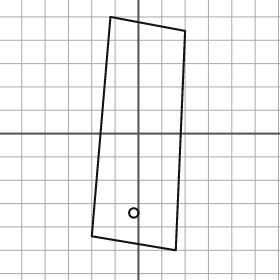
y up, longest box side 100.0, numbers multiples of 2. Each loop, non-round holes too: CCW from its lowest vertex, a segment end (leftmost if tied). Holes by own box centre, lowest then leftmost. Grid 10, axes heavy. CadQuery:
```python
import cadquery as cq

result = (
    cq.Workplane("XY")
    .moveTo(16.0, -50.0)
    .lineTo(20.0, 44.0)
    .lineTo(-12.0, 50.0)
    .lineTo(-20.0, -44.0)
    .close()
    .moveTo(-2.0, -34.0)
    .circle(2.0)
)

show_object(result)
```